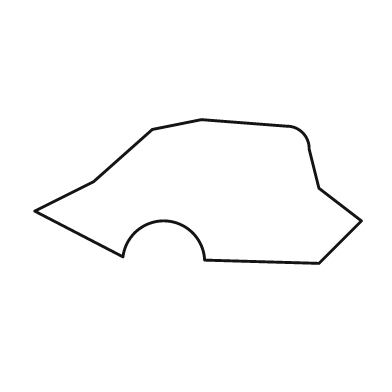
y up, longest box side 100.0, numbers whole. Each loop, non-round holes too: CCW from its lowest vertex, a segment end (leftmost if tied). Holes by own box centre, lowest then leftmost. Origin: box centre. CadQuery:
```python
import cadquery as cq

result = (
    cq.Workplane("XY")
    .moveTo(37.0, -22.0)
    .lineTo(50.0, -9.0)
    .lineTo(37.0, 1.0)
    .lineTo(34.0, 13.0)
    .threePointArc((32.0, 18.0), (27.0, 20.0))
    .lineTo(1.0, 22.0)
    .lineTo(-14.0, 19.0)
    .lineTo(-32.0, 3.0)
    .lineTo(-50.0, -6.0)
    .lineTo(-23.0, -20.0)
    .threePointArc((-10.0, -9.0), (2.0, -21.0))
    .close()
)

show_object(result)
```